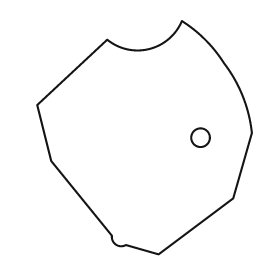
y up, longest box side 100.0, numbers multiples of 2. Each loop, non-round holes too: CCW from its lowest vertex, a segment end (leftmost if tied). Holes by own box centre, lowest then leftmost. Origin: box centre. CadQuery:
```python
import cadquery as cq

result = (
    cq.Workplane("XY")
    .moveTo(6.0, -50.0)
    .lineTo(38.0, -26.0)
    .lineTo(46.0, 2.0)
    .threePointArc((42.0, 18.0), (34.0, 32.0))
    .threePointArc((26.0, 42.0), (16.0, 50.0))
    .threePointArc((2.0, 38.0), (-16.0, 42.0))
    .lineTo(-46.0, 14.0)
    .lineTo(-40.0, -10.0)
    .lineTo(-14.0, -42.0)
    .threePointArc((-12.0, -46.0), (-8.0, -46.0))
    .close()
    .moveTo(24.0, 0.0)
    .circle(4.0)
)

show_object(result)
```